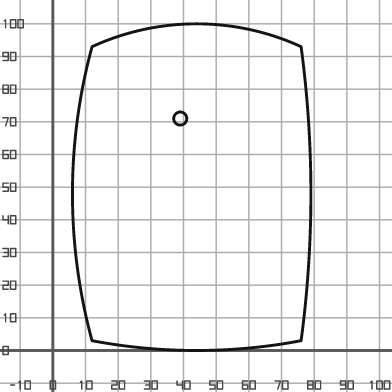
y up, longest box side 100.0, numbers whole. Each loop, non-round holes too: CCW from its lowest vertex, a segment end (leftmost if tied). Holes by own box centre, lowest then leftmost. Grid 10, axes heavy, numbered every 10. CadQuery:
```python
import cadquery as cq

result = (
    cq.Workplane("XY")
    .moveTo(12.0, 3.0)
    .threePointArc((44.0, 0.0), (76.0, 3.0))
    .threePointArc((79.0, 48.0), (76.0, 93.0))
    .threePointArc((44.0, 100.0), (12.0, 93.0))
    .threePointArc((6.0, 48.0), (12.0, 3.0))
    .close()
    .moveTo(39.0, 71.0)
    .circle(2.0)
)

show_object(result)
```